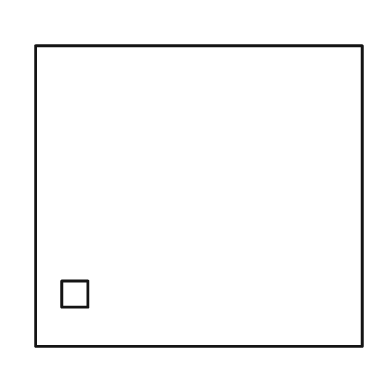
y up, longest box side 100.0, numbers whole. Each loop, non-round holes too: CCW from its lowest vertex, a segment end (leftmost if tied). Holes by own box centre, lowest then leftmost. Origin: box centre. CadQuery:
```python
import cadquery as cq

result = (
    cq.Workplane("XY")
    .moveTo(-50.0, -46.0)
    .lineTo(50.0, -46.0)
    .lineTo(50.0, 46.0)
    .lineTo(-50.0, 46.0)
    .close()
    .moveTo(-42.0, -34.0)
    .lineTo(-34.0, -34.0)
    .lineTo(-34.0, -26.0)
    .lineTo(-42.0, -26.0)
    .close()
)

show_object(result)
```